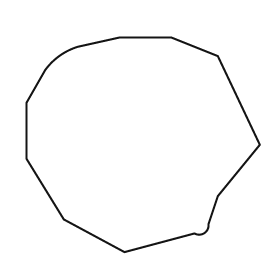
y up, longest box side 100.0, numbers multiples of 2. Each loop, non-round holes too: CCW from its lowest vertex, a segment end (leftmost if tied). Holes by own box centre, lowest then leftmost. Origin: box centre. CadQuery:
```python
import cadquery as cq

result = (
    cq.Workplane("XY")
    .moveTo(-8.0, -46.0)
    .lineTo(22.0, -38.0)
    .threePointArc((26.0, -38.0), (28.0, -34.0))
    .lineTo(32.0, -22.0)
    .lineTo(50.0, 0.0)
    .lineTo(32.0, 38.0)
    .lineTo(12.0, 46.0)
    .lineTo(-10.0, 46.0)
    .lineTo(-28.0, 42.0)
    .threePointArc((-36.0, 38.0), (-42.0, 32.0))
    .lineTo(-50.0, 18.0)
    .lineTo(-50.0, -6.0)
    .lineTo(-34.0, -32.0)
    .close()
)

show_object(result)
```